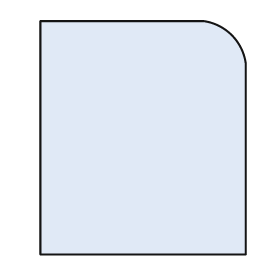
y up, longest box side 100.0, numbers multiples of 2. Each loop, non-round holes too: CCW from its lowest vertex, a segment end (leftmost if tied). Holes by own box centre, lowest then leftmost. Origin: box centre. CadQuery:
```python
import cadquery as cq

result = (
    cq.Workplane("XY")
    .moveTo(-44.0, -50.0)
    .lineTo(44.0, -50.0)
    .lineTo(44.0, 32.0)
    .threePointArc((38.0, 44.0), (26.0, 50.0))
    .lineTo(-44.0, 50.0)
    .close()
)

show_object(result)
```